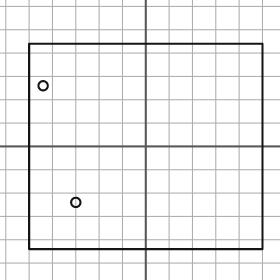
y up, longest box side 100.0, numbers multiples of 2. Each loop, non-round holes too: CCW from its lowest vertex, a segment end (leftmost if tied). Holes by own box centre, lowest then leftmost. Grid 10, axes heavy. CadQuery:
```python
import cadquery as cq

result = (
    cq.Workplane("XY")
    .moveTo(-50.0, -44.0)
    .lineTo(50.0, -44.0)
    .lineTo(50.0, 44.0)
    .lineTo(-50.0, 44.0)
    .close()
    .moveTo(-30.0, -24.0)
    .circle(2.0)
    .moveTo(-44.0, 26.0)
    .circle(2.0)
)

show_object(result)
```